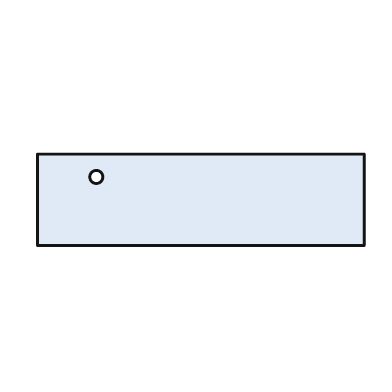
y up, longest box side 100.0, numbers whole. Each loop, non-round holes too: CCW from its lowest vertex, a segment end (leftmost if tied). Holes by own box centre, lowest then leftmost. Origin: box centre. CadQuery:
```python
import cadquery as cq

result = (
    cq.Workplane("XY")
    .moveTo(-50.0, -14.0)
    .lineTo(50.0, -14.0)
    .lineTo(50.0, 14.0)
    .lineTo(-50.0, 14.0)
    .close()
    .moveTo(-32.0, 7.0)
    .circle(2.0)
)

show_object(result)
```